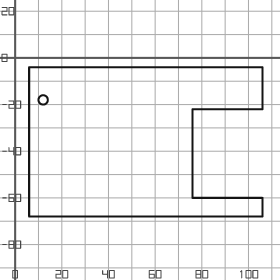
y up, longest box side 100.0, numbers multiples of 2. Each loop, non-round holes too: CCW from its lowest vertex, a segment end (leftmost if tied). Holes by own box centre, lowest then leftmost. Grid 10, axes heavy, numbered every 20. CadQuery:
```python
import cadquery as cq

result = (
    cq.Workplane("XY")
    .moveTo(6.0, -68.0)
    .lineTo(106.0, -68.0)
    .lineTo(106.0, -60.0)
    .lineTo(76.0, -60.0)
    .lineTo(76.0, -22.0)
    .lineTo(106.0, -22.0)
    .lineTo(106.0, -4.0)
    .lineTo(6.0, -4.0)
    .close()
    .moveTo(12.0, -18.0)
    .circle(2.0)
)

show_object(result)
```